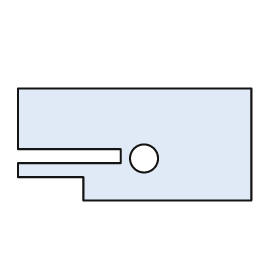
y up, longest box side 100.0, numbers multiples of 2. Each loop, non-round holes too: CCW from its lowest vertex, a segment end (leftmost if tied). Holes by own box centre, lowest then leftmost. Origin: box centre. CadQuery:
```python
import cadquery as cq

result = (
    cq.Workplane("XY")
    .moveTo(-22.0, -24.0)
    .lineTo(50.0, -24.0)
    .lineTo(50.0, 24.0)
    .lineTo(-50.0, 24.0)
    .lineTo(-50.0, -2.0)
    .lineTo(-6.0, -2.0)
    .lineTo(-6.0, -8.0)
    .lineTo(-50.0, -8.0)
    .lineTo(-50.0, -14.0)
    .lineTo(-22.0, -14.0)
    .close()
    .moveTo(4.0, -6.0)
    .circle(6.0)
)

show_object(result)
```